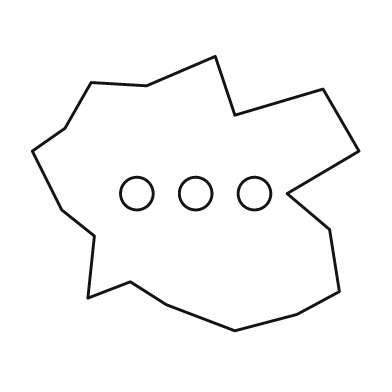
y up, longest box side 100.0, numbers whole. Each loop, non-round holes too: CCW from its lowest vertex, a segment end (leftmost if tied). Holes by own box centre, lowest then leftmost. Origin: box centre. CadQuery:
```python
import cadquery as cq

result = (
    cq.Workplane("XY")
    .moveTo(12.0, -42.0)
    .lineTo(31.0, -37.0)
    .lineTo(44.0, -30.0)
    .lineTo(41.0, -11.0)
    .lineTo(28.0, 0.0)
    .lineTo(50.0, 13.0)
    .lineTo(39.0, 32.0)
    .lineTo(12.0, 24.0)
    .lineTo(6.0, 42.0)
    .lineTo(-15.0, 33.0)
    .lineTo(-32.0, 34.0)
    .lineTo(-40.0, 20.0)
    .lineTo(-50.0, 13.0)
    .lineTo(-41.0, -5.0)
    .lineTo(-31.0, -13.0)
    .lineTo(-33.0, -32.0)
    .lineTo(-20.0, -27.0)
    .lineTo(-9.0, -34.0)
    .close()
    .moveTo(-18.0, 0.0)
    .circle(5.0)
    .moveTo(0.0, 0.0)
    .circle(5.0)
    .moveTo(18.0, 0.0)
    .circle(5.0)
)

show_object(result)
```